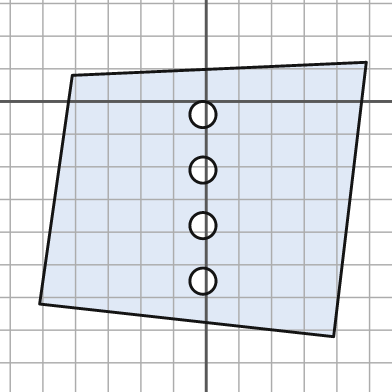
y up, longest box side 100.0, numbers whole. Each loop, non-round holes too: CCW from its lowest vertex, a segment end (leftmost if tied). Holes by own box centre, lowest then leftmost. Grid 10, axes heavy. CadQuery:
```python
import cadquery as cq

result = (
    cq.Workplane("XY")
    .moveTo(39.0, -72.0)
    .lineTo(49.0, 12.0)
    .lineTo(-41.0, 8.0)
    .lineTo(-51.0, -62.0)
    .close()
    .moveTo(-1.0, -55.0)
    .circle(4.0)
    .moveTo(-1.0, -38.0)
    .circle(4.0)
    .moveTo(-1.0, -21.0)
    .circle(4.0)
    .moveTo(-1.0, -4.0)
    .circle(4.0)
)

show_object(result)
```